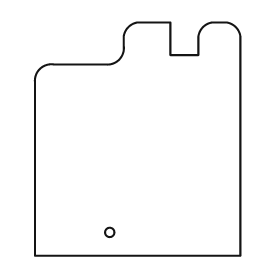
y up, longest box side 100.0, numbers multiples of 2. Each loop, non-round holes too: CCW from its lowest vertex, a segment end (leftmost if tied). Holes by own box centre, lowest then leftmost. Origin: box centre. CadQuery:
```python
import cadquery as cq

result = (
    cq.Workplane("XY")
    .moveTo(-44.0, -50.0)
    .lineTo(44.0, -50.0)
    .lineTo(44.0, 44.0)
    .threePointArc((42.0, 48.0), (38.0, 50.0))
    .lineTo(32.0, 50.0)
    .threePointArc((28.0, 48.0), (26.0, 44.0))
    .lineTo(26.0, 36.0)
    .lineTo(14.0, 36.0)
    .lineTo(14.0, 50.0)
    .lineTo(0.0, 50.0)
    .threePointArc((-4.0, 48.0), (-6.0, 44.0))
    .lineTo(-6.0, 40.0)
    .threePointArc((-8.0, 34.0), (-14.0, 32.0))
    .lineTo(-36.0, 32.0)
    .threePointArc((-42.0, 30.0), (-44.0, 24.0))
    .close()
    .moveTo(-12.0, -40.0)
    .circle(2.0)
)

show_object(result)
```